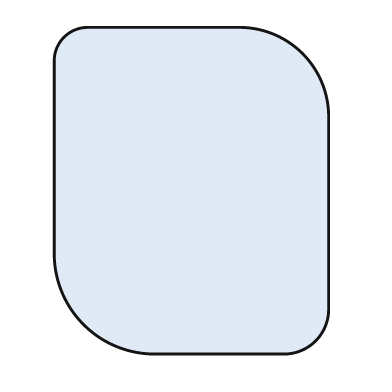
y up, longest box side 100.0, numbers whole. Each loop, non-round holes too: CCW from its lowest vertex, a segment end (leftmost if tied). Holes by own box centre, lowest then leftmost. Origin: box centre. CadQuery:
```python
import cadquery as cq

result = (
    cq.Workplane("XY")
    .moveTo(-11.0, -50.0)
    .lineTo(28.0, -50.0)
    .threePointArc((38.0, -46.0), (42.0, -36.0))
    .lineTo(42.0, 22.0)
    .threePointArc((34.0, 42.0), (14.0, 50.0))
    .lineTo(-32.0, 50.0)
    .threePointArc((-39.0, 47.0), (-42.0, 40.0))
    .lineTo(-42.0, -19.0)
    .threePointArc((-33.0, -41.0), (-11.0, -50.0))
    .close()
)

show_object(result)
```